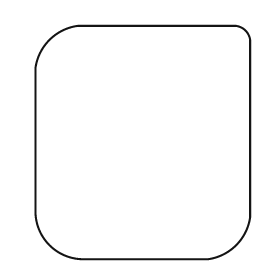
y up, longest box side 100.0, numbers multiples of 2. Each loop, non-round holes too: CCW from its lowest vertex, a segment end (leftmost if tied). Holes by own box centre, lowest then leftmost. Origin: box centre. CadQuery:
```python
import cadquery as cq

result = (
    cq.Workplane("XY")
    .moveTo(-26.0, -50.0)
    .lineTo(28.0, -50.0)
    .threePointArc((40.0, -44.0), (46.0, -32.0))
    .lineTo(46.0, 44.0)
    .threePointArc((44.0, 48.0), (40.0, 50.0))
    .lineTo(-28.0, 50.0)
    .threePointArc((-40.0, 44.0), (-46.0, 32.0))
    .lineTo(-46.0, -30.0)
    .threePointArc((-40.0, -44.0), (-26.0, -50.0))
    .close()
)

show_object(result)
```